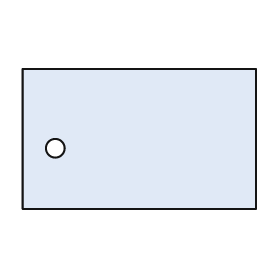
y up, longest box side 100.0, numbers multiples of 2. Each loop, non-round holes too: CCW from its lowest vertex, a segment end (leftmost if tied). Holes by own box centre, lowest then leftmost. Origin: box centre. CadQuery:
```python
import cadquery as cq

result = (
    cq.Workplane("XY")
    .moveTo(-50.0, -30.0)
    .lineTo(50.0, -30.0)
    .lineTo(50.0, 30.0)
    .lineTo(-50.0, 30.0)
    .close()
    .moveTo(-36.0, -4.0)
    .circle(4.0)
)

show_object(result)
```